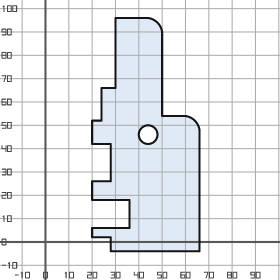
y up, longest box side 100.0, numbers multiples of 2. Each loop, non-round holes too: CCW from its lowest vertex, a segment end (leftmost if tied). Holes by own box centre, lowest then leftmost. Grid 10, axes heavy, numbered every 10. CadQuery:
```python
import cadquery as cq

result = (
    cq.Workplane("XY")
    .moveTo(28.0, -4.0)
    .lineTo(66.0, -4.0)
    .lineTo(66.0, 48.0)
    .threePointArc((64.0, 52.0), (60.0, 54.0))
    .lineTo(50.0, 54.0)
    .lineTo(50.0, 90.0)
    .threePointArc((48.0, 94.0), (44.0, 96.0))
    .lineTo(30.0, 96.0)
    .lineTo(30.0, 66.0)
    .lineTo(24.0, 66.0)
    .lineTo(24.0, 52.0)
    .lineTo(20.0, 52.0)
    .lineTo(20.0, 42.0)
    .lineTo(28.0, 42.0)
    .lineTo(28.0, 26.0)
    .lineTo(20.0, 26.0)
    .lineTo(20.0, 18.0)
    .lineTo(36.0, 18.0)
    .lineTo(36.0, 6.0)
    .lineTo(20.0, 6.0)
    .lineTo(20.0, 2.0)
    .lineTo(28.0, 2.0)
    .close()
    .moveTo(44.0, 46.0)
    .circle(4.0)
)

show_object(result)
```